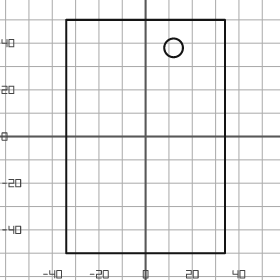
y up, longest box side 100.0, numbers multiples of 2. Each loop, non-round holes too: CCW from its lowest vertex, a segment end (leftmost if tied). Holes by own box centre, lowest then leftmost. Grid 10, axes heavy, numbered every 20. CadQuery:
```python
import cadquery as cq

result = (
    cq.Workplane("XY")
    .moveTo(-34.0, -50.0)
    .lineTo(34.0, -50.0)
    .lineTo(34.0, 50.0)
    .lineTo(-34.0, 50.0)
    .close()
    .moveTo(12.0, 38.0)
    .circle(4.0)
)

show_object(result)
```